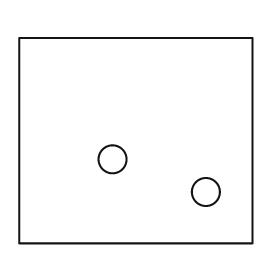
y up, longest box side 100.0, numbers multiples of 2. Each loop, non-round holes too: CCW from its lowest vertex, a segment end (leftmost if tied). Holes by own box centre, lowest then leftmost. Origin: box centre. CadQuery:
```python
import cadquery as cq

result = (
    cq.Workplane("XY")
    .moveTo(-50.0, -44.0)
    .lineTo(50.0, -44.0)
    .lineTo(50.0, 44.0)
    .lineTo(-50.0, 44.0)
    .close()
    .moveTo(30.0, -22.0)
    .circle(6.0)
    .moveTo(-10.0, -8.0)
    .circle(6.0)
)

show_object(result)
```